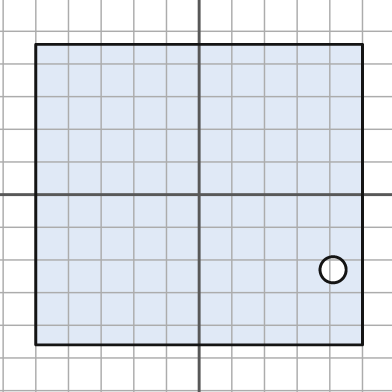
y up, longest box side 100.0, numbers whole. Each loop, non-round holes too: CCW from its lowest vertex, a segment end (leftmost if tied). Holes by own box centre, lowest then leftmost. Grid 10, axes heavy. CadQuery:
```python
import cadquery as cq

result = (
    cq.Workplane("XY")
    .moveTo(-50.0, -46.0)
    .lineTo(50.0, -46.0)
    .lineTo(50.0, 46.0)
    .lineTo(-50.0, 46.0)
    .close()
    .moveTo(41.0, -23.0)
    .circle(4.0)
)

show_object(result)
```